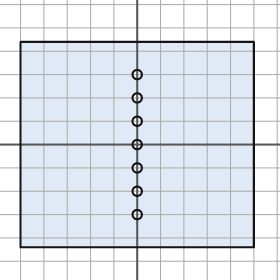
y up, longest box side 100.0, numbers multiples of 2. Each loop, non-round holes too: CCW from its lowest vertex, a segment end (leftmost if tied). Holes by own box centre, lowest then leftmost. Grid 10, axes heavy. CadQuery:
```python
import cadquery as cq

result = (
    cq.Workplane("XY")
    .moveTo(-50.0, -44.0)
    .lineTo(50.0, -44.0)
    .lineTo(50.0, 44.0)
    .lineTo(-50.0, 44.0)
    .close()
    .moveTo(0.0, -30.0)
    .circle(2.0)
    .moveTo(0.0, -20.0)
    .circle(2.0)
    .moveTo(0.0, -10.0)
    .circle(2.0)
    .moveTo(0.0, 0.0)
    .circle(2.0)
    .moveTo(0.0, 10.0)
    .circle(2.0)
    .moveTo(0.0, 20.0)
    .circle(2.0)
    .moveTo(0.0, 30.0)
    .circle(2.0)
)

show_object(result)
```